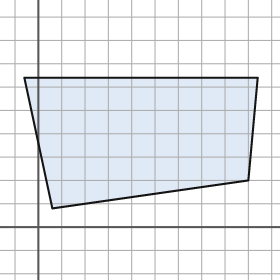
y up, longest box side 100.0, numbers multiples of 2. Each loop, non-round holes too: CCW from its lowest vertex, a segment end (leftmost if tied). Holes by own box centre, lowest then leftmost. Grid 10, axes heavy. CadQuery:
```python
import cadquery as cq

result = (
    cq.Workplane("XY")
    .moveTo(6.0, 8.0)
    .lineTo(90.0, 20.0)
    .lineTo(94.0, 64.0)
    .lineTo(-6.0, 64.0)
    .close()
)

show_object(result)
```